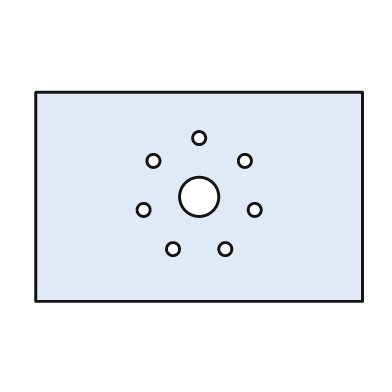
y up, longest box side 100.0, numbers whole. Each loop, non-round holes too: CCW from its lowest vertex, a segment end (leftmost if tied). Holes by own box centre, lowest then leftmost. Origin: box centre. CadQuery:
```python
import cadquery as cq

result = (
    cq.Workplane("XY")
    .moveTo(-50.0, -32.0)
    .lineTo(50.0, -32.0)
    .lineTo(50.0, 32.0)
    .lineTo(-50.0, 32.0)
    .close()
    .moveTo(-8.0, -16.0)
    .circle(2.0)
    .moveTo(8.0, -16.0)
    .circle(2.0)
    .moveTo(-17.0, -4.0)
    .circle(2.0)
    .moveTo(17.0, -4.0)
    .circle(2.0)
    .moveTo(0.0, 0.0)
    .circle(6.0)
    .moveTo(-14.0, 11.0)
    .circle(2.0)
    .moveTo(14.0, 11.0)
    .circle(2.0)
    .moveTo(0.0, 18.0)
    .circle(2.0)
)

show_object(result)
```